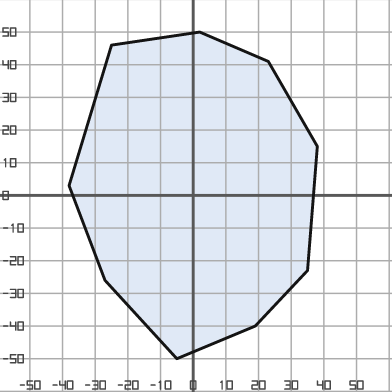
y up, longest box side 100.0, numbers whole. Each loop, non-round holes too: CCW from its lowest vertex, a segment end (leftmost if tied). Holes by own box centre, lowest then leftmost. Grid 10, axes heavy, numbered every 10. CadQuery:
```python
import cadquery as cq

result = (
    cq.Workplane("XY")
    .moveTo(-5.0, -50.0)
    .lineTo(19.0, -40.0)
    .lineTo(35.0, -23.0)
    .lineTo(38.0, 15.0)
    .lineTo(23.0, 41.0)
    .lineTo(2.0, 50.0)
    .lineTo(-25.0, 46.0)
    .lineTo(-38.0, 3.0)
    .lineTo(-27.0, -26.0)
    .close()
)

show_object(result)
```